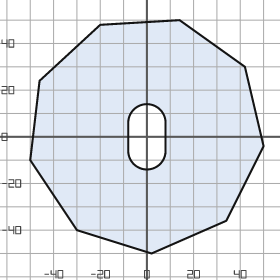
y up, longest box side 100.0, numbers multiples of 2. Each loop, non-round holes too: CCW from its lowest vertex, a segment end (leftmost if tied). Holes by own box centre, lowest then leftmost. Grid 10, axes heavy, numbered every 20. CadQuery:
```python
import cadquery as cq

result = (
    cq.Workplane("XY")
    .moveTo(2.0, -50.0)
    .lineTo(34.0, -36.0)
    .lineTo(50.0, -4.0)
    .lineTo(42.0, 30.0)
    .lineTo(14.0, 50.0)
    .lineTo(-20.0, 48.0)
    .lineTo(-46.0, 24.0)
    .lineTo(-50.0, -10.0)
    .lineTo(-30.0, -40.0)
    .close()
    .moveTo(-8.0, -6.0)
    .threePointArc((0.0, -14.0), (8.0, -6.0))
    .lineTo(8.0, 6.0)
    .threePointArc((0.0, 14.0), (-8.0, 6.0))
    .close()
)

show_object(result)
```